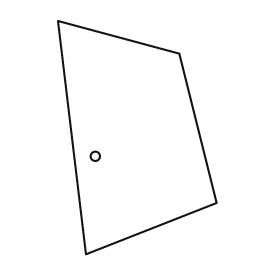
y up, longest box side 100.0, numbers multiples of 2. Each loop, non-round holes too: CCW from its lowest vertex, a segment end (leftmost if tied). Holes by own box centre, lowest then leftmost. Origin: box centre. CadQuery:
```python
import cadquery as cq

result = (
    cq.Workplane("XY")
    .moveTo(-22.0, -50.0)
    .lineTo(34.0, -28.0)
    .lineTo(18.0, 36.0)
    .lineTo(-34.0, 50.0)
    .close()
    .moveTo(-18.0, -8.0)
    .circle(2.0)
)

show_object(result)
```